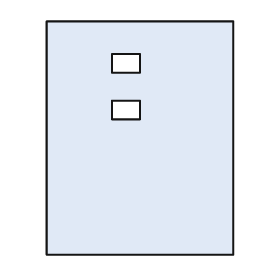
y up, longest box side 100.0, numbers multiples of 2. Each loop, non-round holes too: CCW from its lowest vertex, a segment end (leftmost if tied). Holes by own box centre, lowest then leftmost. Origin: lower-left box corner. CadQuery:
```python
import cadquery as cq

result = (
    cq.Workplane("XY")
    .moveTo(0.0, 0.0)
    .lineTo(80.0, 0.0)
    .lineTo(80.0, 100.0)
    .lineTo(0.0, 100.0)
    .close()
    .moveTo(28.0, 58.0)
    .lineTo(40.0, 58.0)
    .lineTo(40.0, 66.0)
    .lineTo(28.0, 66.0)
    .close()
    .moveTo(28.0, 78.0)
    .lineTo(40.0, 78.0)
    .lineTo(40.0, 86.0)
    .lineTo(28.0, 86.0)
    .close()
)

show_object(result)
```